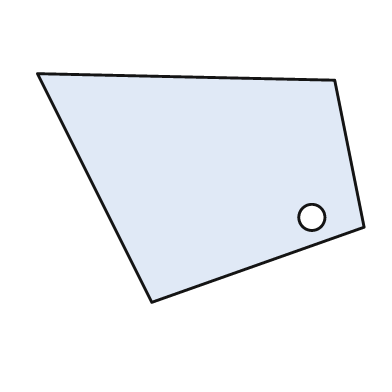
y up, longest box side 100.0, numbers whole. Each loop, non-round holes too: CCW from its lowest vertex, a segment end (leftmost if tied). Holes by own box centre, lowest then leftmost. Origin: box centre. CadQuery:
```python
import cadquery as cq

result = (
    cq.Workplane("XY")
    .moveTo(-15.0, -35.0)
    .lineTo(50.0, -12.0)
    .lineTo(41.0, 33.0)
    .lineTo(-50.0, 35.0)
    .close()
    .moveTo(34.0, -9.0)
    .circle(4.0)
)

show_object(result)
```